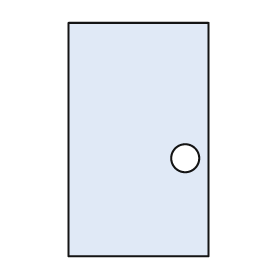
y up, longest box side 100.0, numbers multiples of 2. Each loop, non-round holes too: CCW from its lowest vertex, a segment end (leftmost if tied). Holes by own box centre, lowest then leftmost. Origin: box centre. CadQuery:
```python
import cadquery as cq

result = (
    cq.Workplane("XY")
    .moveTo(-30.0, -50.0)
    .lineTo(30.0, -50.0)
    .lineTo(30.0, 50.0)
    .lineTo(-30.0, 50.0)
    .close()
    .moveTo(20.0, -8.0)
    .circle(6.0)
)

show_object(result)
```